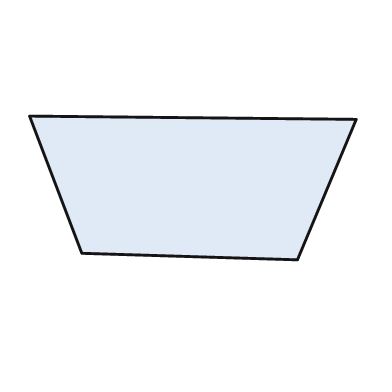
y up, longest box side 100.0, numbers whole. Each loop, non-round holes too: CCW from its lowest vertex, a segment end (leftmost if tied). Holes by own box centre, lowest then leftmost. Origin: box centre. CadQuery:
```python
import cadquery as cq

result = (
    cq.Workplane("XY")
    .moveTo(32.0, -22.0)
    .lineTo(50.0, 21.0)
    .lineTo(-50.0, 22.0)
    .lineTo(-34.0, -20.0)
    .close()
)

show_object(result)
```